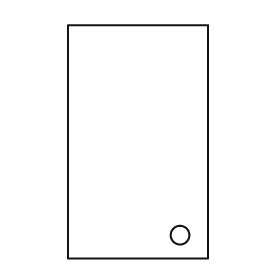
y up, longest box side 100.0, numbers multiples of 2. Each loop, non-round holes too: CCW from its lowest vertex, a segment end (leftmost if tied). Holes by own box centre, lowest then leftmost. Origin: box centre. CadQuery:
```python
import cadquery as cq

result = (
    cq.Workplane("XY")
    .moveTo(-30.0, -50.0)
    .lineTo(30.0, -50.0)
    .lineTo(30.0, 50.0)
    .lineTo(-30.0, 50.0)
    .close()
    .moveTo(18.0, -40.0)
    .circle(4.0)
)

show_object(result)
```